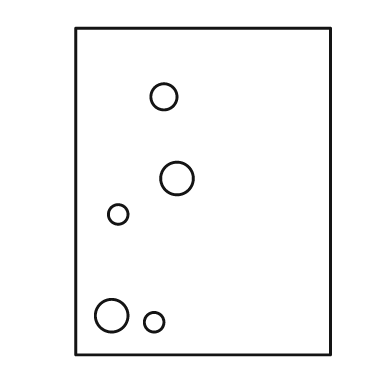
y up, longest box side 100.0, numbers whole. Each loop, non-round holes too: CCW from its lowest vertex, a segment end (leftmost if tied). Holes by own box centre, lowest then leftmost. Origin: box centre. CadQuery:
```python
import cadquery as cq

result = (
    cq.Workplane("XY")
    .moveTo(-39.0, -50.0)
    .lineTo(39.0, -50.0)
    .lineTo(39.0, 50.0)
    .lineTo(-39.0, 50.0)
    .close()
    .moveTo(-15.0, -40.0)
    .circle(3.0)
    .moveTo(-28.0, -38.0)
    .circle(5.0)
    .moveTo(-26.0, -7.0)
    .circle(3.0)
    .moveTo(-8.0, 4.0)
    .circle(5.0)
    .moveTo(-12.0, 29.0)
    .circle(4.0)
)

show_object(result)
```